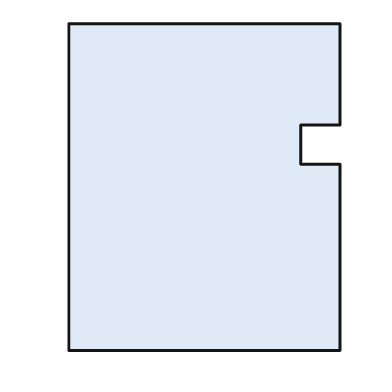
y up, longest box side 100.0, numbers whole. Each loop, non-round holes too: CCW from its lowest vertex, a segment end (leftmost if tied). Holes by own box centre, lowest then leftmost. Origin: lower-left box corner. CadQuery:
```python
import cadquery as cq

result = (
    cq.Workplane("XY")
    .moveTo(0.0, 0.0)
    .lineTo(83.0, 0.0)
    .lineTo(83.0, 57.0)
    .lineTo(71.0, 57.0)
    .lineTo(71.0, 69.0)
    .lineTo(83.0, 69.0)
    .lineTo(83.0, 100.0)
    .lineTo(0.0, 100.0)
    .close()
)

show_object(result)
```